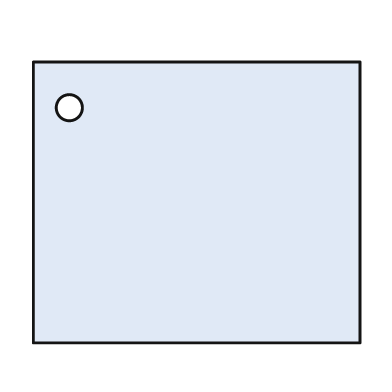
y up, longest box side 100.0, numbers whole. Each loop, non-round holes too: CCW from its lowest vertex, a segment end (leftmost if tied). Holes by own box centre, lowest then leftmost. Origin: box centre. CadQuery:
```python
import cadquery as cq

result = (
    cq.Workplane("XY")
    .moveTo(-50.0, -43.0)
    .lineTo(50.0, -43.0)
    .lineTo(50.0, 43.0)
    .lineTo(-50.0, 43.0)
    .close()
    .moveTo(-39.0, 29.0)
    .circle(4.0)
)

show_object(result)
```